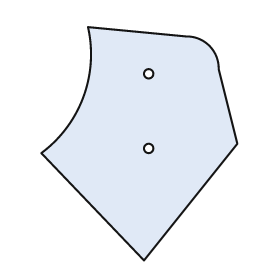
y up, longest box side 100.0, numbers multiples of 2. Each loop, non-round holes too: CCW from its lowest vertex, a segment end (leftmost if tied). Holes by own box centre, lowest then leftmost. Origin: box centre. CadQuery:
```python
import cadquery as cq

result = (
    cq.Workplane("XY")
    .moveTo(2.0, -50.0)
    .lineTo(42.0, 0.0)
    .lineTo(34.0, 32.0)
    .threePointArc((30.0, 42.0), (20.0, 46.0))
    .lineTo(-22.0, 50.0)
    .threePointArc((-24.0, 20.0), (-42.0, -4.0))
    .close()
    .moveTo(4.0, -2.0)
    .circle(2.0)
    .moveTo(4.0, 30.0)
    .circle(2.0)
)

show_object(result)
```